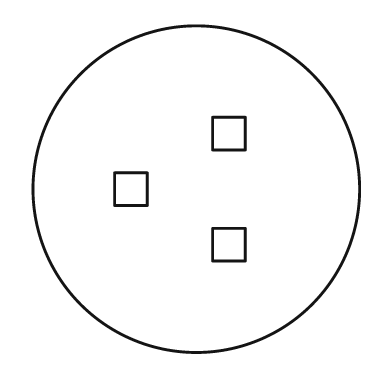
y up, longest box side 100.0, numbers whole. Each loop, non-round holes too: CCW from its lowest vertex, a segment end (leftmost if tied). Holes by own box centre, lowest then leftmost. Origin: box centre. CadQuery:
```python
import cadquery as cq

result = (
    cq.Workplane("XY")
    .moveTo(0.0, 0.0)
    .circle(50.0)
    .moveTo(5.0, -22.0)
    .lineTo(15.0, -22.0)
    .lineTo(15.0, -12.0)
    .lineTo(5.0, -12.0)
    .close()
    .moveTo(-25.0, -5.0)
    .lineTo(-15.0, -5.0)
    .lineTo(-15.0, 5.0)
    .lineTo(-25.0, 5.0)
    .close()
    .moveTo(5.0, 12.0)
    .lineTo(15.0, 12.0)
    .lineTo(15.0, 22.0)
    .lineTo(5.0, 22.0)
    .close()
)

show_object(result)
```